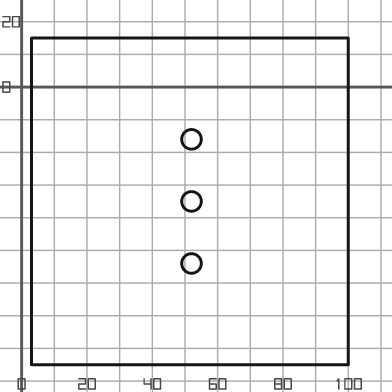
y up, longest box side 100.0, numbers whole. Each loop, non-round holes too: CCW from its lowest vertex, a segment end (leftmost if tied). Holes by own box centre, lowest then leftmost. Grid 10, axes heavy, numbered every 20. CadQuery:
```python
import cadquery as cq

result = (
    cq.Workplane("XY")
    .moveTo(3.0, -85.0)
    .lineTo(100.0, -85.0)
    .lineTo(100.0, 15.0)
    .lineTo(3.0, 15.0)
    .close()
    .moveTo(52.0, -54.0)
    .circle(3.0)
    .moveTo(52.0, -35.0)
    .circle(3.0)
    .moveTo(52.0, -16.0)
    .circle(3.0)
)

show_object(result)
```